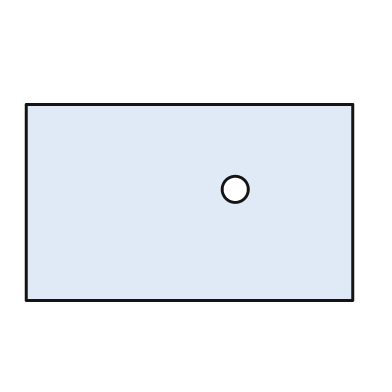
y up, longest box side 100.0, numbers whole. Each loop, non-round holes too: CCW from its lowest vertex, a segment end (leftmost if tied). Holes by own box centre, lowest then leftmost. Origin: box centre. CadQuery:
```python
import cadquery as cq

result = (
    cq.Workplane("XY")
    .moveTo(-50.0, -30.0)
    .lineTo(50.0, -30.0)
    .lineTo(50.0, 30.0)
    .lineTo(-50.0, 30.0)
    .close()
    .moveTo(14.0, 4.0)
    .circle(4.0)
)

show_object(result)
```